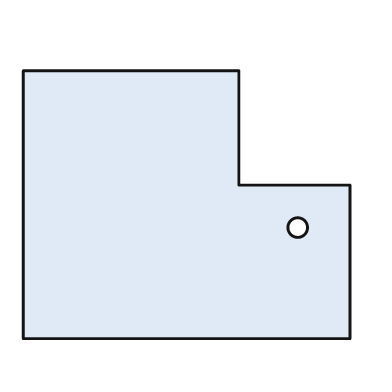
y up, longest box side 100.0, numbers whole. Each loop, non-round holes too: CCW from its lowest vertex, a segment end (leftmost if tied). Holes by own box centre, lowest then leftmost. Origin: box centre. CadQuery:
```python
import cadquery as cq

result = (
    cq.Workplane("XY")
    .moveTo(-50.0, -41.0)
    .lineTo(50.0, -41.0)
    .lineTo(50.0, 6.0)
    .lineTo(16.0, 6.0)
    .lineTo(16.0, 41.0)
    .lineTo(-50.0, 41.0)
    .close()
    .moveTo(34.0, -7.0)
    .circle(3.0)
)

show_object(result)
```